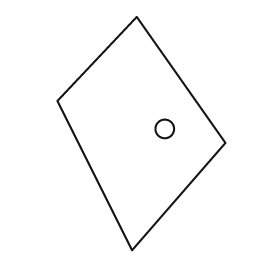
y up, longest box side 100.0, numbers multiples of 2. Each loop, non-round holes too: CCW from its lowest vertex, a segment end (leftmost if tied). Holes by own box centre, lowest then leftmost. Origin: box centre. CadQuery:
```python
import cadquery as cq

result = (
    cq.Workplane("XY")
    .moveTo(-4.0, -50.0)
    .lineTo(36.0, -4.0)
    .lineTo(-2.0, 50.0)
    .lineTo(-36.0, 14.0)
    .close()
    .moveTo(10.0, 2.0)
    .circle(4.0)
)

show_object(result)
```